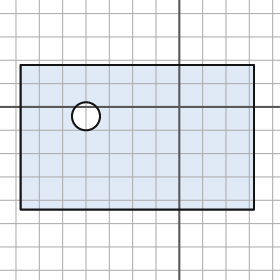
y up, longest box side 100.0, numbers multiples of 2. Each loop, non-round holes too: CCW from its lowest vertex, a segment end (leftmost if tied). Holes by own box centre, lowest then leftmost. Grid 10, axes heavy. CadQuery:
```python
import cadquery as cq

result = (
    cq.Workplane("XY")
    .moveTo(-68.0, -44.0)
    .lineTo(32.0, -44.0)
    .lineTo(32.0, 18.0)
    .lineTo(-68.0, 18.0)
    .close()
    .moveTo(-40.0, -4.0)
    .circle(6.0)
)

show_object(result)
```